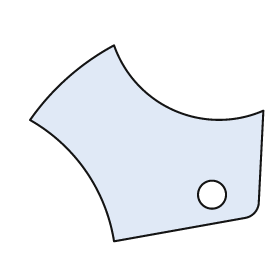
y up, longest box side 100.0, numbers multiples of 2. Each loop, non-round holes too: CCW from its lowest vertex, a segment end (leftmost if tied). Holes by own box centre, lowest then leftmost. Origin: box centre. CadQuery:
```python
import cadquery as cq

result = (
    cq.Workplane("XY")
    .moveTo(-14.0, -42.0)
    .lineTo(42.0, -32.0)
    .threePointArc((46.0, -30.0), (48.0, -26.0))
    .lineTo(50.0, 14.0)
    .threePointArc((12.0, 14.0), (-14.0, 42.0))
    .threePointArc((-34.0, 28.0), (-50.0, 10.0))
    .threePointArc((-26.0, -12.0), (-14.0, -42.0))
    .close()
    .moveTo(28.0, -22.0)
    .circle(6.0)
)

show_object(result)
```